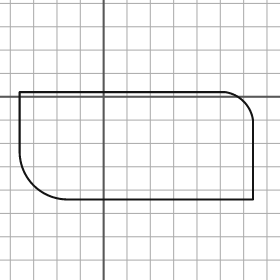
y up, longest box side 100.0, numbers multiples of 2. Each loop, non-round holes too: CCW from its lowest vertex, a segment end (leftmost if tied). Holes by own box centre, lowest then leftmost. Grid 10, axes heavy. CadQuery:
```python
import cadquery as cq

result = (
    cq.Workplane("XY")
    .moveTo(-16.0, -44.0)
    .lineTo(64.0, -44.0)
    .lineTo(64.0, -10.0)
    .threePointArc((60.0, -2.0), (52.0, 2.0))
    .lineTo(-36.0, 2.0)
    .lineTo(-36.0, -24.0)
    .threePointArc((-30.0, -38.0), (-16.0, -44.0))
    .close()
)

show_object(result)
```